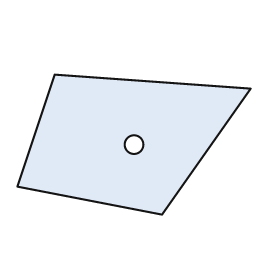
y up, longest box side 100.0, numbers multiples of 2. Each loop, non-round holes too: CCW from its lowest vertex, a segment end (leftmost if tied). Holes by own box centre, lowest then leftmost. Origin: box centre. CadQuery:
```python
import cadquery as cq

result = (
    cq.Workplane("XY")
    .moveTo(12.0, -30.0)
    .lineTo(50.0, 24.0)
    .lineTo(-34.0, 30.0)
    .lineTo(-50.0, -18.0)
    .close()
    .moveTo(0.0, 0.0)
    .circle(4.0)
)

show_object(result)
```